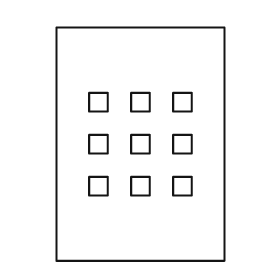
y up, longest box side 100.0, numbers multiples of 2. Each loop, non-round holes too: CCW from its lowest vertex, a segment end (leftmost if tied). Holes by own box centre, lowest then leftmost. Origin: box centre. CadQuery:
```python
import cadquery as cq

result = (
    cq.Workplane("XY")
    .moveTo(-36.0, -50.0)
    .lineTo(36.0, -50.0)
    .lineTo(36.0, 50.0)
    .lineTo(-36.0, 50.0)
    .close()
    .moveTo(-22.0, -22.0)
    .lineTo(-14.0, -22.0)
    .lineTo(-14.0, -14.0)
    .lineTo(-22.0, -14.0)
    .close()
    .moveTo(-4.0, -22.0)
    .lineTo(4.0, -22.0)
    .lineTo(4.0, -14.0)
    .lineTo(-4.0, -14.0)
    .close()
    .moveTo(14.0, -22.0)
    .lineTo(22.0, -22.0)
    .lineTo(22.0, -14.0)
    .lineTo(14.0, -14.0)
    .close()
    .moveTo(-22.0, -4.0)
    .lineTo(-14.0, -4.0)
    .lineTo(-14.0, 4.0)
    .lineTo(-22.0, 4.0)
    .close()
    .moveTo(-4.0, -4.0)
    .lineTo(4.0, -4.0)
    .lineTo(4.0, 4.0)
    .lineTo(-4.0, 4.0)
    .close()
    .moveTo(14.0, -4.0)
    .lineTo(22.0, -4.0)
    .lineTo(22.0, 4.0)
    .lineTo(14.0, 4.0)
    .close()
    .moveTo(-22.0, 14.0)
    .lineTo(-14.0, 14.0)
    .lineTo(-14.0, 22.0)
    .lineTo(-22.0, 22.0)
    .close()
    .moveTo(-4.0, 14.0)
    .lineTo(4.0, 14.0)
    .lineTo(4.0, 22.0)
    .lineTo(-4.0, 22.0)
    .close()
    .moveTo(14.0, 14.0)
    .lineTo(22.0, 14.0)
    .lineTo(22.0, 22.0)
    .lineTo(14.0, 22.0)
    .close()
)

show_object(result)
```